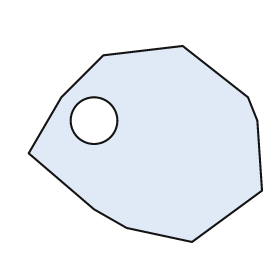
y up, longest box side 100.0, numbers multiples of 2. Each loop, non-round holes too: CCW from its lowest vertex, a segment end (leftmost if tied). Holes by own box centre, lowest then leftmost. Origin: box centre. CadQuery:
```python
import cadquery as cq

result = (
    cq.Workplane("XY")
    .moveTo(20.0, -42.0)
    .lineTo(50.0, -20.0)
    .lineTo(48.0, 10.0)
    .lineTo(44.0, 20.0)
    .lineTo(16.0, 42.0)
    .lineTo(-18.0, 38.0)
    .lineTo(-36.0, 20.0)
    .lineTo(-50.0, -4.0)
    .lineTo(-22.0, -28.0)
    .lineTo(-8.0, -36.0)
    .close()
    .moveTo(-22.0, 10.0)
    .circle(10.0)
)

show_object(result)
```